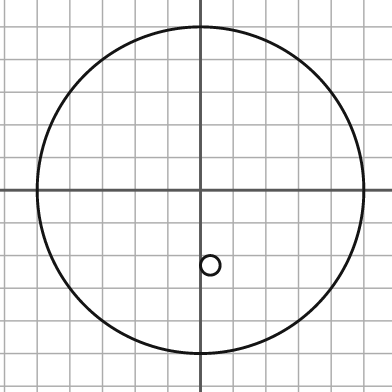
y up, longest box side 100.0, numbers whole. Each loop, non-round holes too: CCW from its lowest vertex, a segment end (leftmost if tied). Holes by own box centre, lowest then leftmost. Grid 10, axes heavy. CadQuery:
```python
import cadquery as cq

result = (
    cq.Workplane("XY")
    .moveTo(0.0, 0.0)
    .circle(50.0)
    .moveTo(3.0, -23.0)
    .circle(3.0)
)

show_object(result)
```